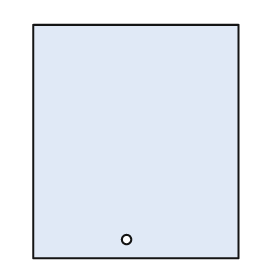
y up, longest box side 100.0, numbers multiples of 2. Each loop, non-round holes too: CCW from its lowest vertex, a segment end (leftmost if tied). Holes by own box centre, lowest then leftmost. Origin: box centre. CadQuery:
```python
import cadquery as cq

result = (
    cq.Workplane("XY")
    .moveTo(-44.0, -50.0)
    .lineTo(44.0, -50.0)
    .lineTo(44.0, 50.0)
    .lineTo(-44.0, 50.0)
    .close()
    .moveTo(-4.0, -42.0)
    .circle(2.0)
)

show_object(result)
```